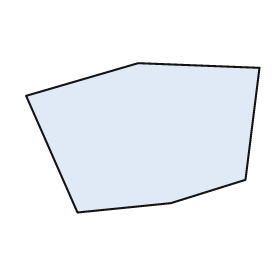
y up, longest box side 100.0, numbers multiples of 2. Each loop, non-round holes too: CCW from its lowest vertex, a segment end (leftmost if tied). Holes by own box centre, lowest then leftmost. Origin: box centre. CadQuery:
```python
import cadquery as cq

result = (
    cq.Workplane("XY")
    .moveTo(-28.0, -32.0)
    .lineTo(12.0, -28.0)
    .lineTo(44.0, -18.0)
    .lineTo(50.0, 30.0)
    .lineTo(-2.0, 32.0)
    .lineTo(-50.0, 18.0)
    .close()
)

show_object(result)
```